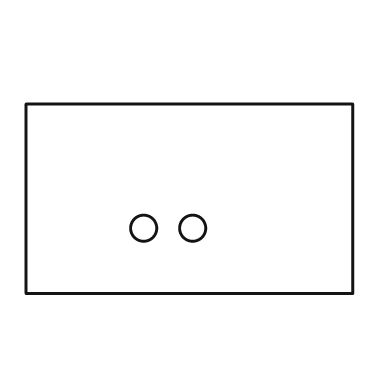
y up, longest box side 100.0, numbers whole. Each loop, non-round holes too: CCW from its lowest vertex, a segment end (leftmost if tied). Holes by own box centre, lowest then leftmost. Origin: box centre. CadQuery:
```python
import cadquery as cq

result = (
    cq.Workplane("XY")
    .moveTo(-50.0, -29.0)
    .lineTo(50.0, -29.0)
    .lineTo(50.0, 29.0)
    .lineTo(-50.0, 29.0)
    .close()
    .moveTo(-14.0, -9.0)
    .circle(4.0)
    .moveTo(1.0, -9.0)
    .circle(4.0)
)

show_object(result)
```